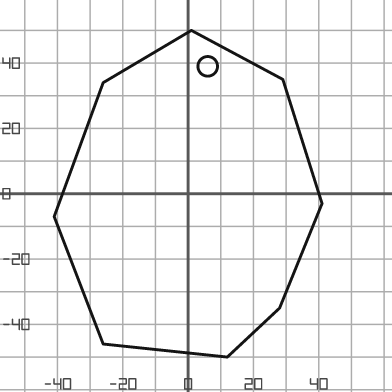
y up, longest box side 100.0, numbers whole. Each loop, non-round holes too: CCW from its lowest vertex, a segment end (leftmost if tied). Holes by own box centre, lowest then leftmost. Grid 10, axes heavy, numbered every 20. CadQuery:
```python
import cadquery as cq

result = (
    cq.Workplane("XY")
    .moveTo(12.0, -50.0)
    .lineTo(28.0, -35.0)
    .lineTo(41.0, -3.0)
    .lineTo(29.0, 35.0)
    .lineTo(1.0, 50.0)
    .lineTo(-26.0, 34.0)
    .lineTo(-41.0, -7.0)
    .lineTo(-26.0, -46.0)
    .close()
    .moveTo(6.0, 39.0)
    .circle(3.0)
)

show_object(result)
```